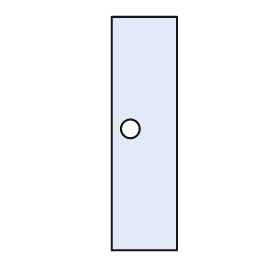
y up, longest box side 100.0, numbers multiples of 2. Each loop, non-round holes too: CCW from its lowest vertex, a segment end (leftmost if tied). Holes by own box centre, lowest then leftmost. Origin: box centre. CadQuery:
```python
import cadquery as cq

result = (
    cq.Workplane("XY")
    .moveTo(-14.0, -50.0)
    .lineTo(14.0, -50.0)
    .lineTo(14.0, 50.0)
    .lineTo(-14.0, 50.0)
    .close()
    .moveTo(-6.0, 2.0)
    .circle(4.0)
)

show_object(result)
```